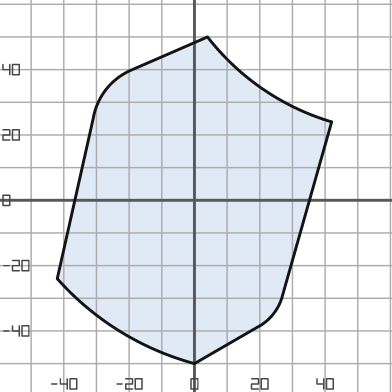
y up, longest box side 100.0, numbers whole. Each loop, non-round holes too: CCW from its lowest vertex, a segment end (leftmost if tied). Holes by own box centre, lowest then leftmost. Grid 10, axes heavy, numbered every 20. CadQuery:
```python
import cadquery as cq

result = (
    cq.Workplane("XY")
    .moveTo(0.0, -50.0)
    .lineTo(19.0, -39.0)
    .threePointArc((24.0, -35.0), (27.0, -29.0))
    .lineTo(42.0, 24.0)
    .threePointArc((21.0, 34.0), (4.0, 50.0))
    .lineTo(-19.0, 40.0)
    .threePointArc((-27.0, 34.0), (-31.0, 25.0))
    .lineTo(-42.0, -24.0)
    .threePointArc((-23.0, -40.0), (0.0, -50.0))
    .close()
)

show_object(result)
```